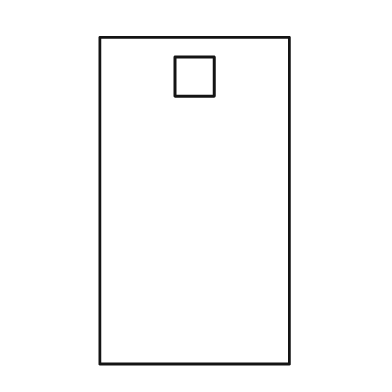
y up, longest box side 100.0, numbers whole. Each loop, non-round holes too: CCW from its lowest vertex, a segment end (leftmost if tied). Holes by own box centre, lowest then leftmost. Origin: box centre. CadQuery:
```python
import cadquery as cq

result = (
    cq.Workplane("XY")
    .moveTo(-29.0, -50.0)
    .lineTo(29.0, -50.0)
    .lineTo(29.0, 50.0)
    .lineTo(-29.0, 50.0)
    .close()
    .moveTo(-6.0, 32.0)
    .lineTo(6.0, 32.0)
    .lineTo(6.0, 44.0)
    .lineTo(-6.0, 44.0)
    .close()
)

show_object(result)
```